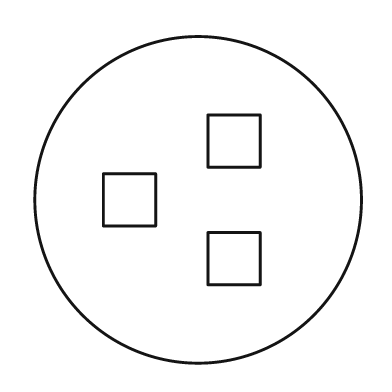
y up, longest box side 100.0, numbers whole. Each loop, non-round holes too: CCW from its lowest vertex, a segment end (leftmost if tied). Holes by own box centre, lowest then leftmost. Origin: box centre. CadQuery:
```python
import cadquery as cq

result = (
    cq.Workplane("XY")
    .moveTo(0.0, 0.0)
    .circle(50.0)
    .moveTo(3.0, -26.0)
    .lineTo(19.0, -26.0)
    .lineTo(19.0, -10.0)
    .lineTo(3.0, -10.0)
    .close()
    .moveTo(-29.0, -8.0)
    .lineTo(-13.0, -8.0)
    .lineTo(-13.0, 8.0)
    .lineTo(-29.0, 8.0)
    .close()
    .moveTo(3.0, 10.0)
    .lineTo(19.0, 10.0)
    .lineTo(19.0, 26.0)
    .lineTo(3.0, 26.0)
    .close()
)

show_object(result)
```